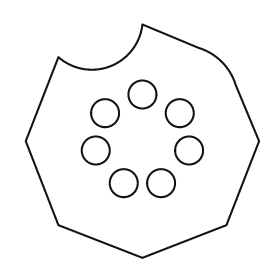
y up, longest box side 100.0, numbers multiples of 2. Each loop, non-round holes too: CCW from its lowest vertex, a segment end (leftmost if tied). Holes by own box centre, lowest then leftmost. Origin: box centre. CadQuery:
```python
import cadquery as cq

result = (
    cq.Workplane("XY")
    .moveTo(0.0, -50.0)
    .lineTo(36.0, -36.0)
    .lineTo(50.0, 0.0)
    .lineTo(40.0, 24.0)
    .threePointArc((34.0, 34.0), (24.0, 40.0))
    .lineTo(0.0, 50.0)
    .threePointArc((-14.0, 32.0), (-36.0, 36.0))
    .lineTo(-50.0, 0.0)
    .lineTo(-36.0, -36.0)
    .close()
    .moveTo(-8.0, -18.0)
    .circle(6.0)
    .moveTo(8.0, -18.0)
    .circle(6.0)
    .moveTo(-20.0, -4.0)
    .circle(6.0)
    .moveTo(20.0, -4.0)
    .circle(6.0)
    .moveTo(-16.0, 12.0)
    .circle(6.0)
    .moveTo(16.0, 12.0)
    .circle(6.0)
    .moveTo(0.0, 20.0)
    .circle(6.0)
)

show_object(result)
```